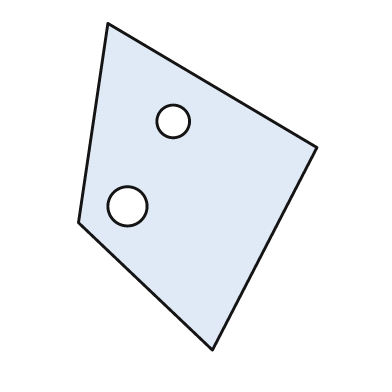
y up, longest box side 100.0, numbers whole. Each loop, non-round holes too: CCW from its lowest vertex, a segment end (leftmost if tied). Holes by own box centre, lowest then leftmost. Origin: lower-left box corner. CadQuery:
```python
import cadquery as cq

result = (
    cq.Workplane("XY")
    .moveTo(41.0, 0.0)
    .lineTo(73.0, 62.0)
    .lineTo(9.0, 100.0)
    .lineTo(0.0, 39.0)
    .close()
    .moveTo(15.0, 44.0)
    .circle(6.0)
    .moveTo(29.0, 70.0)
    .circle(5.0)
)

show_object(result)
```